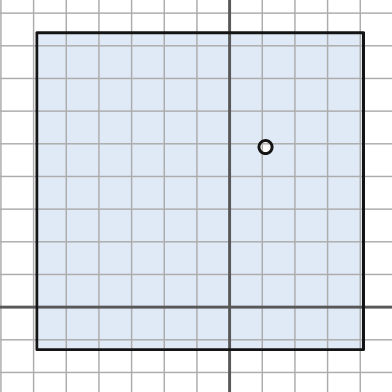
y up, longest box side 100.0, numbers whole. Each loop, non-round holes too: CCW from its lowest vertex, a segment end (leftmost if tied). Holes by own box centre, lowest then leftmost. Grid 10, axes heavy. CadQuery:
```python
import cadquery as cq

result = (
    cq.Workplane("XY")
    .moveTo(-59.0, -13.0)
    .lineTo(41.0, -13.0)
    .lineTo(41.0, 84.0)
    .lineTo(-59.0, 84.0)
    .close()
    .moveTo(11.0, 49.0)
    .circle(2.0)
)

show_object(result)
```